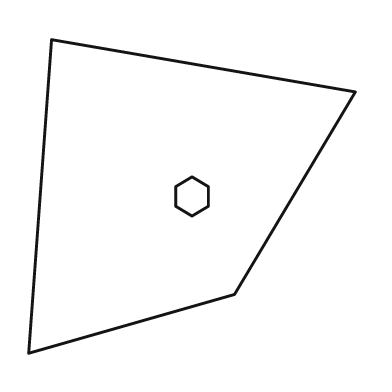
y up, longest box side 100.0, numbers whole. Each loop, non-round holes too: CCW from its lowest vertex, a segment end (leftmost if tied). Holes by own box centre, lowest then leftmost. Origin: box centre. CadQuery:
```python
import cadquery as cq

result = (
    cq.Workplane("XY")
    .moveTo(-50.0, -48.0)
    .lineTo(13.0, -30.0)
    .lineTo(50.0, 32.0)
    .lineTo(-43.0, 48.0)
    .close()
    .moveTo(0.0, -6.0)
    .lineTo(5.0, -3.0)
    .lineTo(5.0, 3.0)
    .lineTo(0.0, 6.0)
    .lineTo(-5.0, 3.0)
    .lineTo(-5.0, -3.0)
    .close()
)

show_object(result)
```